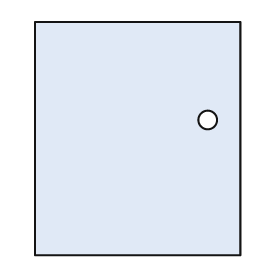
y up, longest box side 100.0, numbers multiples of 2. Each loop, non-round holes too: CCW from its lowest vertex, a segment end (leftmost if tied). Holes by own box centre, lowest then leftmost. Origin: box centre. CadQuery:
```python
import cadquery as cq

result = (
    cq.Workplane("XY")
    .moveTo(-44.0, -50.0)
    .lineTo(44.0, -50.0)
    .lineTo(44.0, 50.0)
    .lineTo(-44.0, 50.0)
    .close()
    .moveTo(30.0, 8.0)
    .circle(4.0)
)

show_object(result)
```